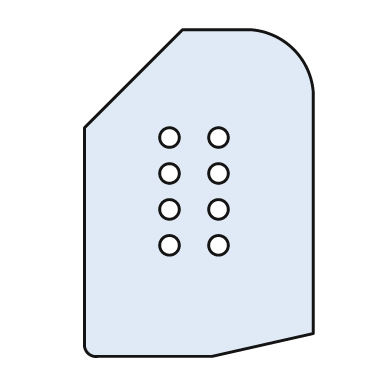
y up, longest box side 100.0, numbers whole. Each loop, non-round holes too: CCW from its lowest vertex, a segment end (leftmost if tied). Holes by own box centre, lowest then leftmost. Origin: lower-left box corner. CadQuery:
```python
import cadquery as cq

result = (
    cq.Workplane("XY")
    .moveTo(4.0, 0.0)
    .lineTo(39.0, 0.0)
    .lineTo(70.0, 7.0)
    .lineTo(70.0, 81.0)
    .threePointArc((64.0, 94.0), (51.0, 100.0))
    .lineTo(30.0, 100.0)
    .lineTo(0.0, 70.0)
    .lineTo(0.0, 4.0)
    .threePointArc((1.0, 1.0), (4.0, 0.0))
    .close()
    .moveTo(26.0, 34.0)
    .circle(3.0)
    .moveTo(41.0, 34.0)
    .circle(3.0)
    .moveTo(26.0, 45.0)
    .circle(3.0)
    .moveTo(41.0, 45.0)
    .circle(3.0)
    .moveTo(26.0, 56.0)
    .circle(3.0)
    .moveTo(41.0, 56.0)
    .circle(3.0)
    .moveTo(26.0, 67.0)
    .circle(3.0)
    .moveTo(41.0, 67.0)
    .circle(3.0)
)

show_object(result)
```